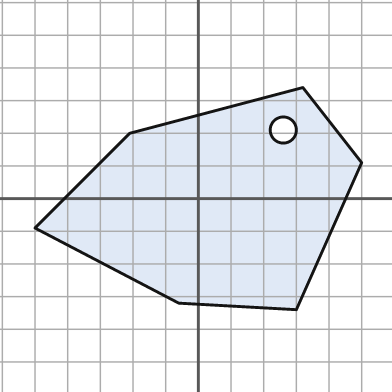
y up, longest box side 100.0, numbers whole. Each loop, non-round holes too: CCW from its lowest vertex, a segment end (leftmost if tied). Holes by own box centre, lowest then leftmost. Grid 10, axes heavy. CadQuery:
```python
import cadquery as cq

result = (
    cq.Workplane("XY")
    .moveTo(30.0, -34.0)
    .lineTo(50.0, 11.0)
    .lineTo(32.0, 34.0)
    .lineTo(-21.0, 20.0)
    .lineTo(-50.0, -9.0)
    .lineTo(-6.0, -32.0)
    .close()
    .moveTo(26.0, 21.0)
    .circle(4.0)
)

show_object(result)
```